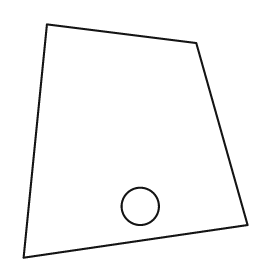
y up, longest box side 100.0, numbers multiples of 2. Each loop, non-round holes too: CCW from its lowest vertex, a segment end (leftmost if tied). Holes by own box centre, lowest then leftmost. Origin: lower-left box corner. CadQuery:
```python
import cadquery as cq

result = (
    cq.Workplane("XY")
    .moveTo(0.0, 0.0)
    .lineTo(96.0, 14.0)
    .lineTo(74.0, 92.0)
    .lineTo(10.0, 100.0)
    .close()
    .moveTo(50.0, 22.0)
    .circle(8.0)
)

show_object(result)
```